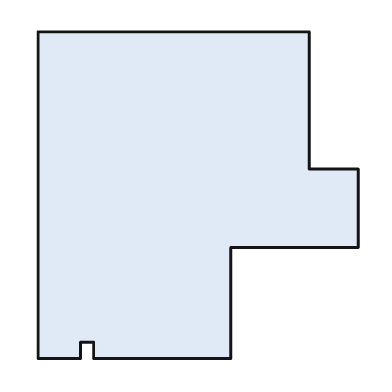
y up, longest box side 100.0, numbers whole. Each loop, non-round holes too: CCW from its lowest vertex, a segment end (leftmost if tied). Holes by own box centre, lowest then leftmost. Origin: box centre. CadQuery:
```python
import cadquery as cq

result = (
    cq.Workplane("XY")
    .moveTo(-49.0, -50.0)
    .lineTo(-36.0, -50.0)
    .lineTo(-36.0, -45.0)
    .lineTo(-32.0, -45.0)
    .lineTo(-32.0, -50.0)
    .lineTo(10.0, -50.0)
    .lineTo(10.0, -16.0)
    .lineTo(49.0, -16.0)
    .lineTo(49.0, 8.0)
    .lineTo(34.0, 8.0)
    .lineTo(34.0, 50.0)
    .lineTo(-49.0, 50.0)
    .close()
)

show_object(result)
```